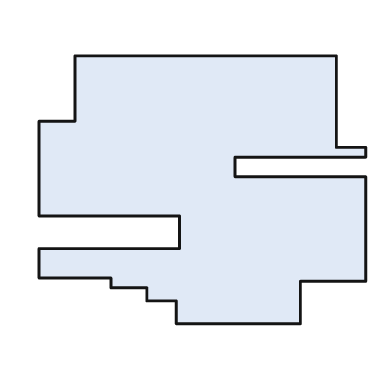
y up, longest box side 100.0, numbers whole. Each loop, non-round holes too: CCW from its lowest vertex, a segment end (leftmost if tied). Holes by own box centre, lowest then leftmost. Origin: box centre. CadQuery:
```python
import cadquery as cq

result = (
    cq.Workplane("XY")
    .moveTo(-8.0, -41.0)
    .lineTo(30.0, -41.0)
    .lineTo(30.0, -28.0)
    .lineTo(50.0, -28.0)
    .lineTo(50.0, 4.0)
    .lineTo(10.0, 4.0)
    .lineTo(10.0, 10.0)
    .lineTo(50.0, 10.0)
    .lineTo(50.0, 13.0)
    .lineTo(41.0, 13.0)
    .lineTo(41.0, 41.0)
    .lineTo(-39.0, 41.0)
    .lineTo(-39.0, 21.0)
    .lineTo(-50.0, 21.0)
    .lineTo(-50.0, -8.0)
    .lineTo(-7.0, -8.0)
    .lineTo(-7.0, -18.0)
    .lineTo(-50.0, -18.0)
    .lineTo(-50.0, -27.0)
    .lineTo(-28.0, -27.0)
    .lineTo(-28.0, -30.0)
    .lineTo(-17.0, -30.0)
    .lineTo(-17.0, -34.0)
    .lineTo(-8.0, -34.0)
    .close()
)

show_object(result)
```